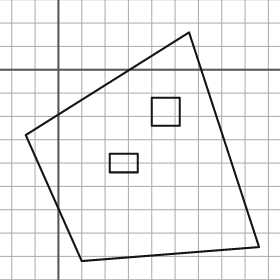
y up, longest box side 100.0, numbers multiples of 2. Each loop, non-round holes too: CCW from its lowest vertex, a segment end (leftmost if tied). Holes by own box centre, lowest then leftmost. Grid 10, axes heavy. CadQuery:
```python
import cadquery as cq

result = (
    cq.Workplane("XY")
    .moveTo(10.0, -82.0)
    .lineTo(86.0, -76.0)
    .lineTo(56.0, 16.0)
    .lineTo(-14.0, -28.0)
    .close()
    .moveTo(22.0, -44.0)
    .lineTo(34.0, -44.0)
    .lineTo(34.0, -36.0)
    .lineTo(22.0, -36.0)
    .close()
    .moveTo(40.0, -24.0)
    .lineTo(52.0, -24.0)
    .lineTo(52.0, -12.0)
    .lineTo(40.0, -12.0)
    .close()
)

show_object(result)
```